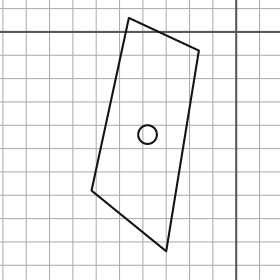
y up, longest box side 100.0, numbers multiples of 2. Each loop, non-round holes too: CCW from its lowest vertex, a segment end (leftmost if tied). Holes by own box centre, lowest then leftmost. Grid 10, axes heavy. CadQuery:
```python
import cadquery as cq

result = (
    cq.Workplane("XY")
    .moveTo(-30.0, -94.0)
    .lineTo(-16.0, -8.0)
    .lineTo(-46.0, 6.0)
    .lineTo(-62.0, -68.0)
    .close()
    .moveTo(-38.0, -44.0)
    .circle(4.0)
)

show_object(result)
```